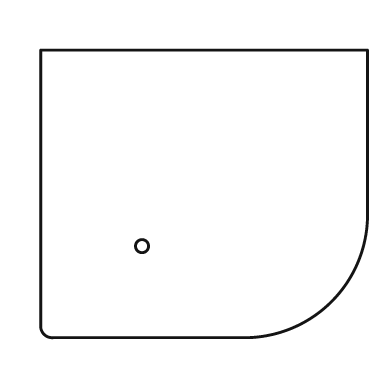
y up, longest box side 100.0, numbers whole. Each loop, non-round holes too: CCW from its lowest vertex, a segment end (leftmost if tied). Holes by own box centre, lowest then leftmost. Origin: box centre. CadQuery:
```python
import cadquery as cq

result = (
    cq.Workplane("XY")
    .moveTo(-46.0, -44.0)
    .lineTo(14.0, -44.0)
    .threePointArc((39.0, -33.0), (50.0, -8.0))
    .lineTo(50.0, 44.0)
    .lineTo(-50.0, 44.0)
    .lineTo(-50.0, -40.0)
    .threePointArc((-49.0, -43.0), (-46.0, -44.0))
    .close()
    .moveTo(-19.0, -16.0)
    .circle(2.0)
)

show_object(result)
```